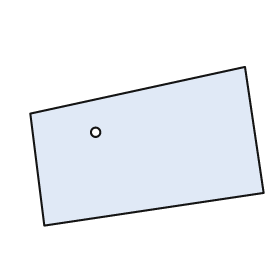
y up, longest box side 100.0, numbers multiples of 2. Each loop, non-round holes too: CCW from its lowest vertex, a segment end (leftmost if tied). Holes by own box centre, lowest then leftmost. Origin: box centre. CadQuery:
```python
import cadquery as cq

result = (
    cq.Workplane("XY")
    .moveTo(-44.0, -34.0)
    .lineTo(50.0, -20.0)
    .lineTo(42.0, 34.0)
    .lineTo(-50.0, 14.0)
    .close()
    .moveTo(-22.0, 6.0)
    .circle(2.0)
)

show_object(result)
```